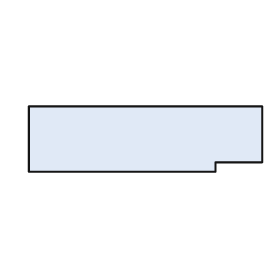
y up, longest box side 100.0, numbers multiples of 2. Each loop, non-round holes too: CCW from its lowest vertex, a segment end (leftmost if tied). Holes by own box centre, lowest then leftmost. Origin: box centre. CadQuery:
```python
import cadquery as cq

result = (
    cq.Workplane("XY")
    .moveTo(-50.0, -14.0)
    .lineTo(30.0, -14.0)
    .lineTo(30.0, -10.0)
    .lineTo(50.0, -10.0)
    .lineTo(50.0, 14.0)
    .lineTo(-50.0, 14.0)
    .close()
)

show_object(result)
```